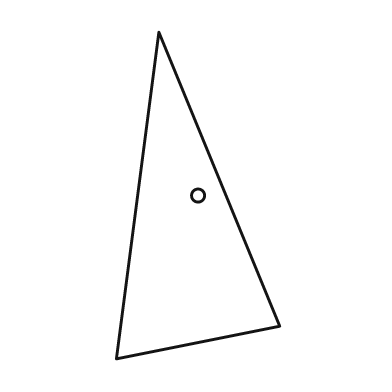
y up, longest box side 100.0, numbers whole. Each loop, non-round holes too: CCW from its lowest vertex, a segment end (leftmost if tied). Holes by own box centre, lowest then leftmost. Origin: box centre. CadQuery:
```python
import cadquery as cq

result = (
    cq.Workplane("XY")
    .moveTo(-25.0, -50.0)
    .lineTo(25.0, -40.0)
    .lineTo(-12.0, 50.0)
    .close()
    .moveTo(0.0, 0.0)
    .circle(2.0)
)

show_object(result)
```